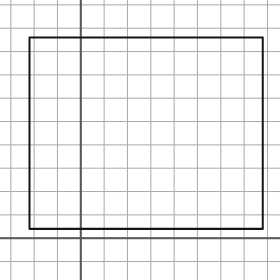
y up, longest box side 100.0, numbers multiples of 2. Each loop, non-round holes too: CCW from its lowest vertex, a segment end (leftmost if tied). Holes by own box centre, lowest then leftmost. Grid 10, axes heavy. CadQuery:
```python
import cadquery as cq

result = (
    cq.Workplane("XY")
    .moveTo(-22.0, 4.0)
    .lineTo(78.0, 4.0)
    .lineTo(78.0, 86.0)
    .lineTo(-22.0, 86.0)
    .close()
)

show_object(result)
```